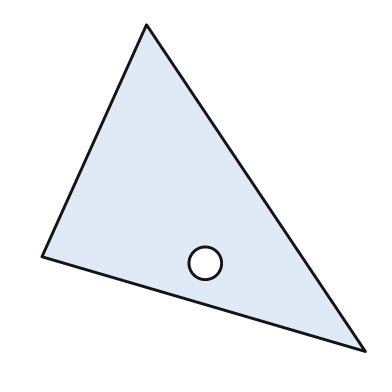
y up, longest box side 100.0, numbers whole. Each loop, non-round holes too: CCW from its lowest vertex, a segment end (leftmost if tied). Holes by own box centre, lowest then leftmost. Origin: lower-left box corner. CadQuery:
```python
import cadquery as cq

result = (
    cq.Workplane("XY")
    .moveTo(99.0, 0.0)
    .lineTo(32.0, 100.0)
    .lineTo(0.0, 29.0)
    .close()
    .moveTo(50.0, 27.0)
    .circle(5.0)
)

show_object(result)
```